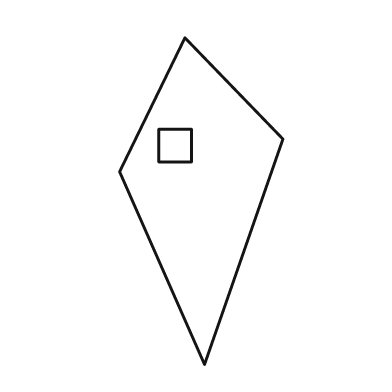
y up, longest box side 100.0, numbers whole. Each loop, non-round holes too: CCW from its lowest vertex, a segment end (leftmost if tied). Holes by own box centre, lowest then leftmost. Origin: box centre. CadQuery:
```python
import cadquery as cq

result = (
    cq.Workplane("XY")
    .moveTo(1.0, -50.0)
    .lineTo(25.0, 19.0)
    .lineTo(-5.0, 50.0)
    .lineTo(-25.0, 9.0)
    .close()
    .moveTo(-13.0, 12.0)
    .lineTo(-3.0, 12.0)
    .lineTo(-3.0, 22.0)
    .lineTo(-13.0, 22.0)
    .close()
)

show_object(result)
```